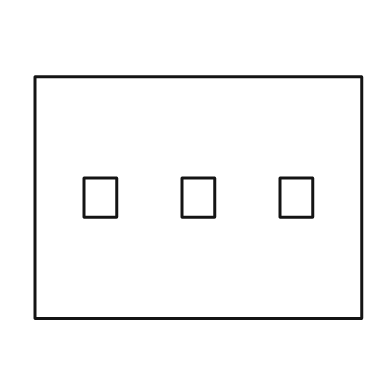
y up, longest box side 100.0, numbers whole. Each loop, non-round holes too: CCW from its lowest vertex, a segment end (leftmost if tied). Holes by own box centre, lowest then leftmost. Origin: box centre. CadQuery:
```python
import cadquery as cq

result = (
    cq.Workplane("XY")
    .moveTo(-50.0, -37.0)
    .lineTo(50.0, -37.0)
    .lineTo(50.0, 37.0)
    .lineTo(-50.0, 37.0)
    .close()
    .moveTo(-35.0, -6.0)
    .lineTo(-25.0, -6.0)
    .lineTo(-25.0, 6.0)
    .lineTo(-35.0, 6.0)
    .close()
    .moveTo(-5.0, -6.0)
    .lineTo(5.0, -6.0)
    .lineTo(5.0, 6.0)
    .lineTo(-5.0, 6.0)
    .close()
    .moveTo(25.0, -6.0)
    .lineTo(35.0, -6.0)
    .lineTo(35.0, 6.0)
    .lineTo(25.0, 6.0)
    .close()
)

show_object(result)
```